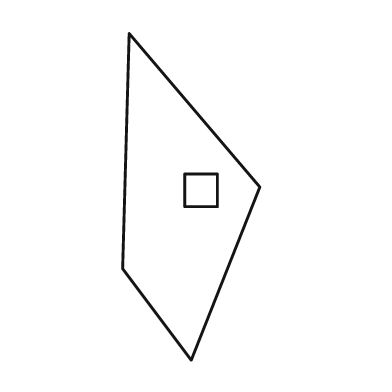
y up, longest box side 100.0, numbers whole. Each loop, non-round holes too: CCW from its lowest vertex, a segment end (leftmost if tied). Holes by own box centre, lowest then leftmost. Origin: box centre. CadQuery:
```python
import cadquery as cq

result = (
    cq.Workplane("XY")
    .moveTo(0.0, -50.0)
    .lineTo(21.0, 3.0)
    .lineTo(-19.0, 50.0)
    .lineTo(-21.0, -22.0)
    .close()
    .moveTo(-2.0, -3.0)
    .lineTo(8.0, -3.0)
    .lineTo(8.0, 7.0)
    .lineTo(-2.0, 7.0)
    .close()
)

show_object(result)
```